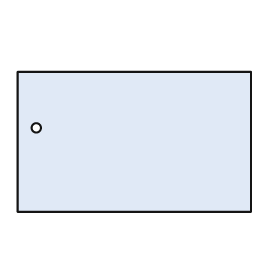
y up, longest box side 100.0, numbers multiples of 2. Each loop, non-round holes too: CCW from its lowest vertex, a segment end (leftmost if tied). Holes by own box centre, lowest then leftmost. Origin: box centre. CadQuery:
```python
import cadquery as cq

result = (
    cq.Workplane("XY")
    .moveTo(-50.0, -30.0)
    .lineTo(50.0, -30.0)
    .lineTo(50.0, 30.0)
    .lineTo(-50.0, 30.0)
    .close()
    .moveTo(-42.0, 6.0)
    .circle(2.0)
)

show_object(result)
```